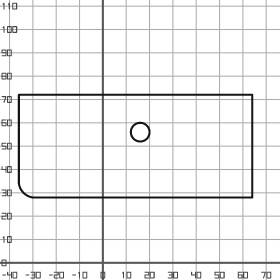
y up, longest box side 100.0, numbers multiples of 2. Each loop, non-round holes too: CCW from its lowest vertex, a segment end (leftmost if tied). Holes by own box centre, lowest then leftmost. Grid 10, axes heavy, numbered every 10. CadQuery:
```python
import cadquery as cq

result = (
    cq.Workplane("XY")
    .moveTo(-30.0, 28.0)
    .lineTo(64.0, 28.0)
    .lineTo(64.0, 72.0)
    .lineTo(-36.0, 72.0)
    .lineTo(-36.0, 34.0)
    .threePointArc((-34.0, 30.0), (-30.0, 28.0))
    .close()
    .moveTo(16.0, 56.0)
    .circle(4.0)
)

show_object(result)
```